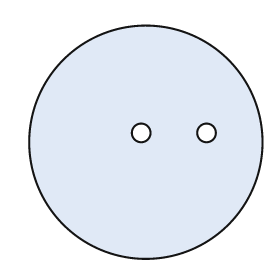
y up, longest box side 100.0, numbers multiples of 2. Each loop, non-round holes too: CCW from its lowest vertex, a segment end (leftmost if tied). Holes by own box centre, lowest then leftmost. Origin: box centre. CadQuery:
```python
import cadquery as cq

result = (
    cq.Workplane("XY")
    .moveTo(0.0, 0.0)
    .circle(50.0)
    .moveTo(-2.0, 4.0)
    .circle(4.0)
    .moveTo(26.0, 4.0)
    .circle(4.0)
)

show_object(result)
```